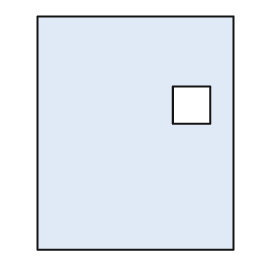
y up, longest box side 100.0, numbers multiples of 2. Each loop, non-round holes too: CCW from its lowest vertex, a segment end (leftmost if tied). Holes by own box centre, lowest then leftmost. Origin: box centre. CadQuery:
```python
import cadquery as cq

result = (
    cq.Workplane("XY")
    .moveTo(-42.0, -50.0)
    .lineTo(42.0, -50.0)
    .lineTo(42.0, 50.0)
    .lineTo(-42.0, 50.0)
    .close()
    .moveTo(16.0, 4.0)
    .lineTo(32.0, 4.0)
    .lineTo(32.0, 20.0)
    .lineTo(16.0, 20.0)
    .close()
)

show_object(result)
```